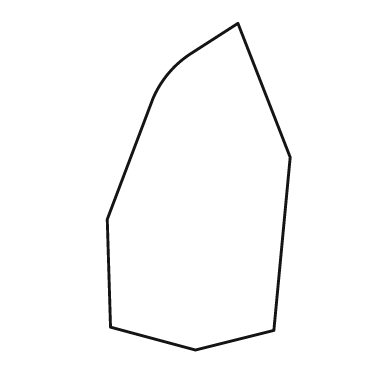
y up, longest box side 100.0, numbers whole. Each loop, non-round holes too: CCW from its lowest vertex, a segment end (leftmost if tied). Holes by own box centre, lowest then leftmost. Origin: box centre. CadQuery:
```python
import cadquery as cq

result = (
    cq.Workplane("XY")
    .moveTo(-1.0, -50.0)
    .lineTo(23.0, -44.0)
    .lineTo(28.0, 9.0)
    .lineTo(12.0, 50.0)
    .lineTo(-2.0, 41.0)
    .threePointArc((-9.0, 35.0), (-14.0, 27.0))
    .lineTo(-28.0, -10.0)
    .lineTo(-27.0, -43.0)
    .close()
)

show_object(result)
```